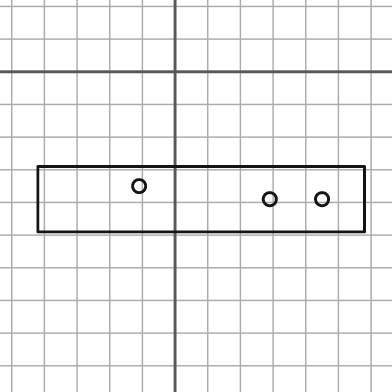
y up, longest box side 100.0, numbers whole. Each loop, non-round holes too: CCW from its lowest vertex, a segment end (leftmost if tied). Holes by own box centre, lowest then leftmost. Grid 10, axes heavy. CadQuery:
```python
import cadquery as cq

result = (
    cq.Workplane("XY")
    .moveTo(-42.0, -49.0)
    .lineTo(58.0, -49.0)
    .lineTo(58.0, -29.0)
    .lineTo(-42.0, -29.0)
    .close()
    .moveTo(29.0, -39.0)
    .circle(2.0)
    .moveTo(45.0, -39.0)
    .circle(2.0)
    .moveTo(-11.0, -35.0)
    .circle(2.0)
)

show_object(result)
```